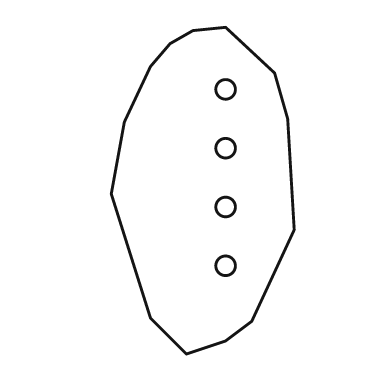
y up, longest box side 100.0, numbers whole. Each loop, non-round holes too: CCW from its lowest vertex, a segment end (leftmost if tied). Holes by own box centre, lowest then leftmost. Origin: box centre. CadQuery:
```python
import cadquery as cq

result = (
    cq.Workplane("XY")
    .moveTo(-5.0, -50.0)
    .lineTo(7.0, -46.0)
    .lineTo(15.0, -40.0)
    .lineTo(28.0, -12.0)
    .lineTo(26.0, 22.0)
    .lineTo(22.0, 36.0)
    .lineTo(7.0, 50.0)
    .lineTo(-3.0, 49.0)
    .lineTo(-10.0, 45.0)
    .lineTo(-16.0, 38.0)
    .lineTo(-24.0, 21.0)
    .lineTo(-28.0, -1.0)
    .lineTo(-16.0, -39.0)
    .close()
    .moveTo(7.0, -23.0)
    .circle(3.0)
    .moveTo(7.0, -5.0)
    .circle(3.0)
    .moveTo(7.0, 13.0)
    .circle(3.0)
    .moveTo(7.0, 31.0)
    .circle(3.0)
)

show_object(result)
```